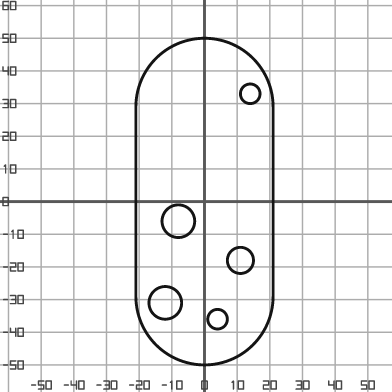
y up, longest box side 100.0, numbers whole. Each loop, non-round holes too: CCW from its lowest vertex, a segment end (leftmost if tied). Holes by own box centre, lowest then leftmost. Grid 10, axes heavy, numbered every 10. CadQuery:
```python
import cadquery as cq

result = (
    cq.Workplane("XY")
    .moveTo(-21.0, -29.0)
    .threePointArc((0.0, -50.0), (21.0, -29.0))
    .lineTo(21.0, 29.0)
    .threePointArc((0.0, 50.0), (-21.0, 29.0))
    .close()
    .moveTo(4.0, -36.0)
    .circle(3.0)
    .moveTo(-12.0, -31.0)
    .circle(5.0)
    .moveTo(11.0, -18.0)
    .circle(4.0)
    .moveTo(-8.0, -6.0)
    .circle(5.0)
    .moveTo(14.0, 33.0)
    .circle(3.0)
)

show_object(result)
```